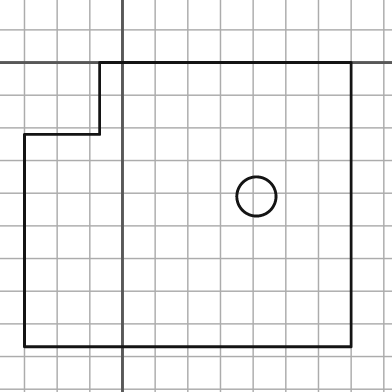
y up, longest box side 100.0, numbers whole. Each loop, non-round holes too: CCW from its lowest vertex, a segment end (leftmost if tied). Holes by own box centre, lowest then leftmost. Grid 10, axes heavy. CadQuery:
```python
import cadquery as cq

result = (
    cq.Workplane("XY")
    .moveTo(-30.0, -87.0)
    .lineTo(70.0, -87.0)
    .lineTo(70.0, 0.0)
    .lineTo(-7.0, 0.0)
    .lineTo(-7.0, -22.0)
    .lineTo(-30.0, -22.0)
    .close()
    .moveTo(41.0, -41.0)
    .circle(6.0)
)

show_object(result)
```